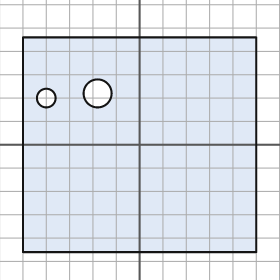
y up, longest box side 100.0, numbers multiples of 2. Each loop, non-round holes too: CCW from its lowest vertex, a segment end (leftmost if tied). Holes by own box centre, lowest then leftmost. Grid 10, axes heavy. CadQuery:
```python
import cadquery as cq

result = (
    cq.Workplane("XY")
    .moveTo(-50.0, -46.0)
    .lineTo(50.0, -46.0)
    .lineTo(50.0, 46.0)
    .lineTo(-50.0, 46.0)
    .close()
    .moveTo(-40.0, 20.0)
    .circle(4.0)
    .moveTo(-18.0, 22.0)
    .circle(6.0)
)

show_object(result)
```